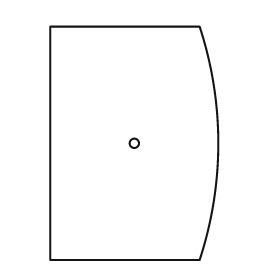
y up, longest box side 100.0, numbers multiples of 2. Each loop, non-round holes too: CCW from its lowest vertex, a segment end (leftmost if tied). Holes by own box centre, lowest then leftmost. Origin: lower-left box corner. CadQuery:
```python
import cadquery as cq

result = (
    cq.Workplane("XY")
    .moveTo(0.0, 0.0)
    .lineTo(64.0, 0.0)
    .threePointArc((72.0, 50.0), (64.0, 100.0))
    .lineTo(0.0, 100.0)
    .close()
    .moveTo(36.0, 50.0)
    .circle(2.0)
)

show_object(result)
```